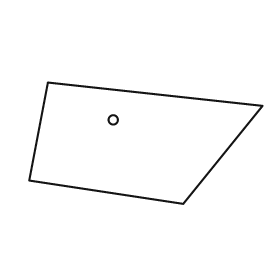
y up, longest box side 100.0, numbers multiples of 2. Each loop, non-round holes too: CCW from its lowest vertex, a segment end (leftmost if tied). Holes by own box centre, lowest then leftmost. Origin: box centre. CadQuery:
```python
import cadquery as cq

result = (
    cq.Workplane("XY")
    .moveTo(16.0, -26.0)
    .lineTo(50.0, 16.0)
    .lineTo(-42.0, 26.0)
    .lineTo(-50.0, -16.0)
    .close()
    .moveTo(-14.0, 10.0)
    .circle(2.0)
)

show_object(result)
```